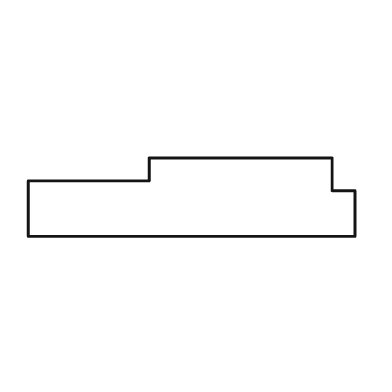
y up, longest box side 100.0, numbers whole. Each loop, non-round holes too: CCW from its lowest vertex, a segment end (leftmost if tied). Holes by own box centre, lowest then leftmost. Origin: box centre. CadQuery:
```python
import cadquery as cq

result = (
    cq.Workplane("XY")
    .moveTo(-50.0, -12.0)
    .lineTo(50.0, -12.0)
    .lineTo(50.0, 2.0)
    .lineTo(43.0, 2.0)
    .lineTo(43.0, 12.0)
    .lineTo(-13.0, 12.0)
    .lineTo(-13.0, 5.0)
    .lineTo(-50.0, 5.0)
    .close()
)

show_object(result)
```